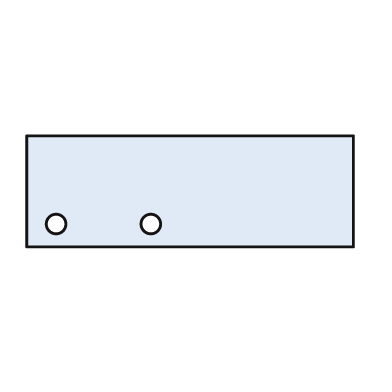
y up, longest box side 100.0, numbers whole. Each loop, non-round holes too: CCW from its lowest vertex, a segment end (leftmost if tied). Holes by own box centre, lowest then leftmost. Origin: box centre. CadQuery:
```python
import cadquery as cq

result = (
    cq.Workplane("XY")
    .moveTo(-50.0, -17.0)
    .lineTo(50.0, -17.0)
    .lineTo(50.0, 17.0)
    .lineTo(-50.0, 17.0)
    .close()
    .moveTo(-41.0, -10.0)
    .circle(3.0)
    .moveTo(-12.0, -10.0)
    .circle(3.0)
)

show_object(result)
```